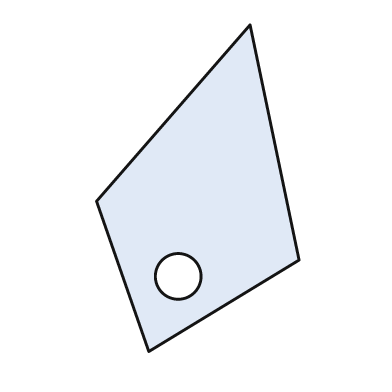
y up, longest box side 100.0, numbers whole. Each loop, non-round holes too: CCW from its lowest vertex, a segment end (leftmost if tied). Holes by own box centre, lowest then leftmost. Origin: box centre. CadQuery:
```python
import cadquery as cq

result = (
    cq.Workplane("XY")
    .moveTo(-15.0, -50.0)
    .lineTo(31.0, -22.0)
    .lineTo(16.0, 50.0)
    .lineTo(-31.0, -4.0)
    .close()
    .moveTo(-6.0, -27.0)
    .circle(7.0)
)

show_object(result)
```